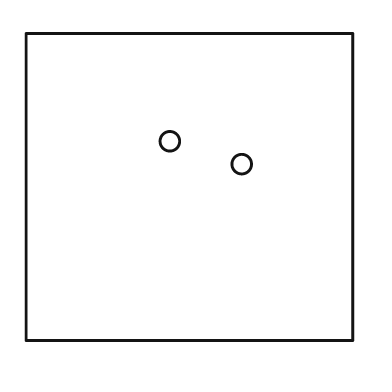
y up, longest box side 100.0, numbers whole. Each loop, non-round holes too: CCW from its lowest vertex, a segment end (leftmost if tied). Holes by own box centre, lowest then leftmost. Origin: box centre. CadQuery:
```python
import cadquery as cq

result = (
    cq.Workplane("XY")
    .moveTo(-50.0, -47.0)
    .lineTo(50.0, -47.0)
    .lineTo(50.0, 47.0)
    .lineTo(-50.0, 47.0)
    .close()
    .moveTo(16.0, 7.0)
    .circle(3.0)
    .moveTo(-6.0, 14.0)
    .circle(3.0)
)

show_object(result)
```